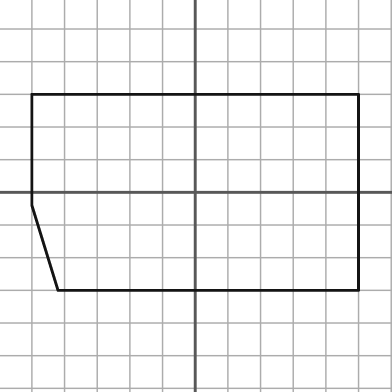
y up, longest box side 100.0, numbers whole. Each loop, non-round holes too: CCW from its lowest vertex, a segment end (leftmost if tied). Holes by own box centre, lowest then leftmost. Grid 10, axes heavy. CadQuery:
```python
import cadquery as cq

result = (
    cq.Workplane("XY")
    .moveTo(-42.0, -30.0)
    .lineTo(50.0, -30.0)
    .lineTo(50.0, 30.0)
    .lineTo(-50.0, 30.0)
    .lineTo(-50.0, -4.0)
    .close()
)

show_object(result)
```